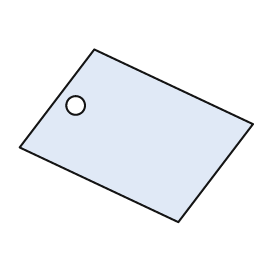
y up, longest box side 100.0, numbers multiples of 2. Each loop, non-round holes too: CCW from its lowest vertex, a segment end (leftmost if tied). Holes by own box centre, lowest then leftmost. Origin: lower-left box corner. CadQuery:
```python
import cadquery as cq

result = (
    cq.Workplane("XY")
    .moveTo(68.0, 0.0)
    .lineTo(100.0, 42.0)
    .lineTo(32.0, 74.0)
    .lineTo(0.0, 32.0)
    .close()
    .moveTo(24.0, 50.0)
    .circle(4.0)
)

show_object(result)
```